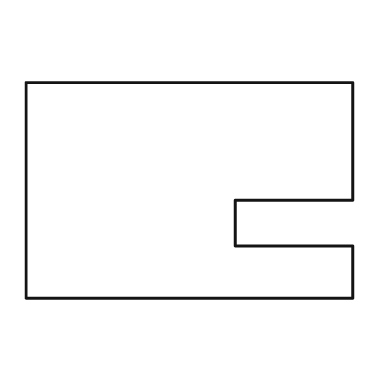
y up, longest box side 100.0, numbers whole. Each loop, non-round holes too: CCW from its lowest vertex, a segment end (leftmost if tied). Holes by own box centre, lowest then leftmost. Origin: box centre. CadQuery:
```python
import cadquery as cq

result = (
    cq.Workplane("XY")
    .moveTo(-50.0, -33.0)
    .lineTo(50.0, -33.0)
    .lineTo(50.0, -17.0)
    .lineTo(14.0, -17.0)
    .lineTo(14.0, -3.0)
    .lineTo(50.0, -3.0)
    .lineTo(50.0, 33.0)
    .lineTo(-50.0, 33.0)
    .close()
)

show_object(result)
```